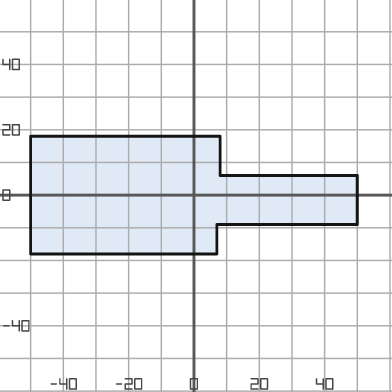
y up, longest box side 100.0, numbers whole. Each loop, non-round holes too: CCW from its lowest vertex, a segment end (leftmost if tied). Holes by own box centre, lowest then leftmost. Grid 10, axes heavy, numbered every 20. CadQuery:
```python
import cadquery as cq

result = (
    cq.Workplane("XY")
    .moveTo(-50.0, -18.0)
    .lineTo(7.0, -18.0)
    .lineTo(7.0, -9.0)
    .lineTo(50.0, -9.0)
    .lineTo(50.0, 6.0)
    .lineTo(8.0, 6.0)
    .lineTo(8.0, 18.0)
    .lineTo(-50.0, 18.0)
    .close()
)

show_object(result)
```